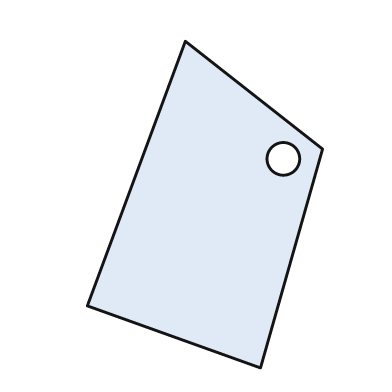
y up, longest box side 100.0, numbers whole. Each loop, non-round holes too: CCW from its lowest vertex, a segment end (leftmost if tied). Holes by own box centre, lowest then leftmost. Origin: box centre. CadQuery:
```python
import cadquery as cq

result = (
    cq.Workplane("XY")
    .moveTo(17.0, -50.0)
    .lineTo(36.0, 17.0)
    .lineTo(-6.0, 50.0)
    .lineTo(-36.0, -31.0)
    .close()
    .moveTo(24.0, 14.0)
    .circle(5.0)
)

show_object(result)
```